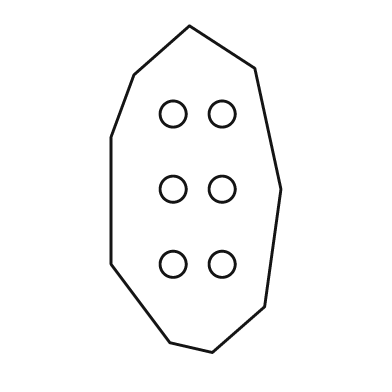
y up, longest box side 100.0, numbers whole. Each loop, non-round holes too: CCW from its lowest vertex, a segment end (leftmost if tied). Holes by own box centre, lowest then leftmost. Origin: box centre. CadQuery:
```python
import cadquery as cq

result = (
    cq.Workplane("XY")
    .moveTo(5.0, -50.0)
    .lineTo(21.0, -36.0)
    .lineTo(26.0, 0.0)
    .lineTo(18.0, 37.0)
    .lineTo(-2.0, 50.0)
    .lineTo(-19.0, 35.0)
    .lineTo(-26.0, 16.0)
    .lineTo(-26.0, -23.0)
    .lineTo(-8.0, -47.0)
    .close()
    .moveTo(-7.0, -23.0)
    .circle(4.0)
    .moveTo(8.0, -23.0)
    .circle(4.0)
    .moveTo(-7.0, 0.0)
    .circle(4.0)
    .moveTo(8.0, 0.0)
    .circle(4.0)
    .moveTo(-7.0, 23.0)
    .circle(4.0)
    .moveTo(8.0, 23.0)
    .circle(4.0)
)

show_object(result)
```